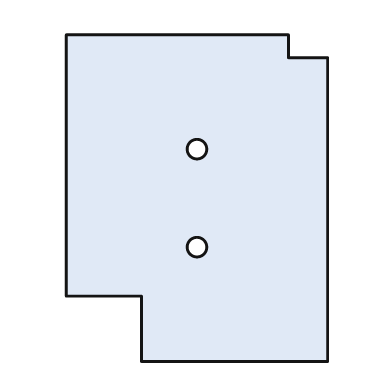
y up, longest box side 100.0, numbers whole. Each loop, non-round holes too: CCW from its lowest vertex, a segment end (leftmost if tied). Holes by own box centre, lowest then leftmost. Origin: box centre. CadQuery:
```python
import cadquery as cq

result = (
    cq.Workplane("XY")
    .moveTo(-17.0, -50.0)
    .lineTo(40.0, -50.0)
    .lineTo(40.0, 43.0)
    .lineTo(28.0, 43.0)
    .lineTo(28.0, 50.0)
    .lineTo(-40.0, 50.0)
    .lineTo(-40.0, -30.0)
    .lineTo(-17.0, -30.0)
    .close()
    .moveTo(0.0, -15.0)
    .circle(3.0)
    .moveTo(0.0, 15.0)
    .circle(3.0)
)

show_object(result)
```